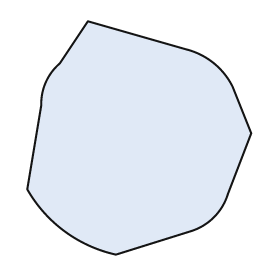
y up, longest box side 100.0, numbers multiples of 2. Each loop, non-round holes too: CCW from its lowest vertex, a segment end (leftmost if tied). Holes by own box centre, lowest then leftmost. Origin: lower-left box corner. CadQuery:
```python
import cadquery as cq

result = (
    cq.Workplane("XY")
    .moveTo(38.0, 0.0)
    .lineTo(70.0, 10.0)
    .threePointArc((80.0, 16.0), (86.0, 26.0))
    .lineTo(96.0, 52.0)
    .lineTo(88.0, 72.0)
    .threePointArc((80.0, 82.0), (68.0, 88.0))
    .lineTo(26.0, 100.0)
    .lineTo(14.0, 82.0)
    .threePointArc((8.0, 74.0), (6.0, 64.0))
    .lineTo(0.0, 28.0)
    .threePointArc((16.0, 10.0), (38.0, 0.0))
    .close()
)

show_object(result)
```